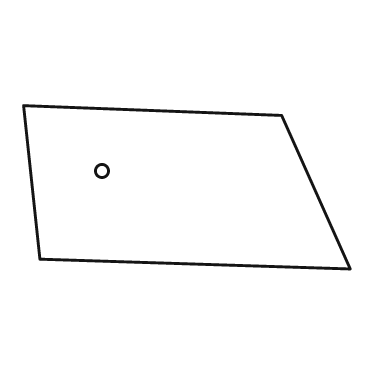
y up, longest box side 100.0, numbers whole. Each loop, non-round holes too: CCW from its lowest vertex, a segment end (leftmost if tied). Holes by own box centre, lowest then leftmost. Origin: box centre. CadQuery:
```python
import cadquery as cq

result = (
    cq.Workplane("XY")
    .moveTo(50.0, -25.0)
    .lineTo(29.0, 22.0)
    .lineTo(-50.0, 25.0)
    .lineTo(-45.0, -22.0)
    .close()
    .moveTo(-26.0, 5.0)
    .circle(2.0)
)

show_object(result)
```